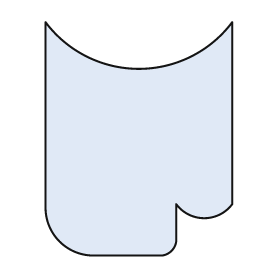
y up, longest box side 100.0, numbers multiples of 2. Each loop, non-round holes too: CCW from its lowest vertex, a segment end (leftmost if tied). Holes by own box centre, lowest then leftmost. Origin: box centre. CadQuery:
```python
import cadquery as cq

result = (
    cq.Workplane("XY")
    .moveTo(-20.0, -50.0)
    .lineTo(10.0, -50.0)
    .threePointArc((14.0, -48.0), (16.0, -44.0))
    .lineTo(16.0, -28.0)
    .threePointArc((28.0, -34.0), (40.0, -28.0))
    .lineTo(40.0, 50.0)
    .threePointArc((0.0, 30.0), (-40.0, 50.0))
    .lineTo(-40.0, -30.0)
    .threePointArc((-34.0, -44.0), (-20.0, -50.0))
    .close()
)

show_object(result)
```